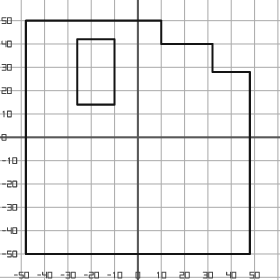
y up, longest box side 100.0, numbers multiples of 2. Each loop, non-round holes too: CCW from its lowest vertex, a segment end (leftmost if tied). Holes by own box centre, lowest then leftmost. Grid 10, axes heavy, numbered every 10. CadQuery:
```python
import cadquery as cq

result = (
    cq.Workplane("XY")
    .moveTo(-48.0, -50.0)
    .lineTo(48.0, -50.0)
    .lineTo(48.0, 28.0)
    .lineTo(32.0, 28.0)
    .lineTo(32.0, 40.0)
    .lineTo(10.0, 40.0)
    .lineTo(10.0, 50.0)
    .lineTo(-48.0, 50.0)
    .close()
    .moveTo(-26.0, 14.0)
    .lineTo(-10.0, 14.0)
    .lineTo(-10.0, 42.0)
    .lineTo(-26.0, 42.0)
    .close()
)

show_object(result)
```